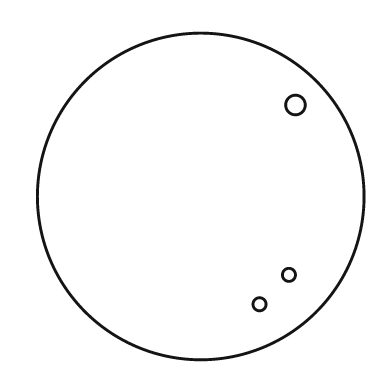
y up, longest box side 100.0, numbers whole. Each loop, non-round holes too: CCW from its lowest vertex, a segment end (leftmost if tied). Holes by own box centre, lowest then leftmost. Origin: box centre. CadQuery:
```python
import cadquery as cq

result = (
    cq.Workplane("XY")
    .moveTo(0.0, 0.0)
    .circle(50.0)
    .moveTo(18.0, -33.0)
    .circle(2.0)
    .moveTo(27.0, -24.0)
    .circle(2.0)
    .moveTo(29.0, 28.0)
    .circle(3.0)
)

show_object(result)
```